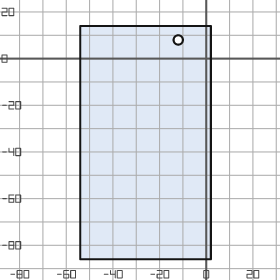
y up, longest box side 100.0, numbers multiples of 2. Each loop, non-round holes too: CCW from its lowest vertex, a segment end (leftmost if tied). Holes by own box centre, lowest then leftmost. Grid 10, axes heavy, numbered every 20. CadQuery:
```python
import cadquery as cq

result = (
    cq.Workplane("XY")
    .moveTo(-54.0, -86.0)
    .lineTo(2.0, -86.0)
    .lineTo(2.0, 14.0)
    .lineTo(-54.0, 14.0)
    .close()
    .moveTo(-12.0, 8.0)
    .circle(2.0)
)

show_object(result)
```